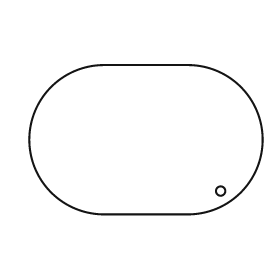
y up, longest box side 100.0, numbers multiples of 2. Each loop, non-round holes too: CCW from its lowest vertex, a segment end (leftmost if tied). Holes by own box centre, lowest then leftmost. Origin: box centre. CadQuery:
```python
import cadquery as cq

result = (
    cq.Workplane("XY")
    .moveTo(-18.0, -32.0)
    .lineTo(18.0, -32.0)
    .threePointArc((50.0, 0.0), (18.0, 32.0))
    .lineTo(-18.0, 32.0)
    .threePointArc((-50.0, 0.0), (-18.0, -32.0))
    .close()
    .moveTo(32.0, -22.0)
    .circle(2.0)
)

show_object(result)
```